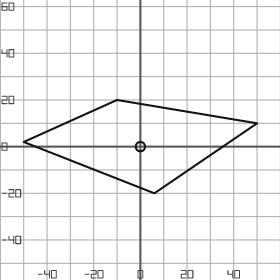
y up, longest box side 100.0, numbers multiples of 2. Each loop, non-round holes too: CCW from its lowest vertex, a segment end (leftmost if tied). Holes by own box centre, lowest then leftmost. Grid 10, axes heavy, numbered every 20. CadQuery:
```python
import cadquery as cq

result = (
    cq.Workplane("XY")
    .moveTo(6.0, -20.0)
    .lineTo(50.0, 10.0)
    .lineTo(-10.0, 20.0)
    .lineTo(-50.0, 2.0)
    .close()
    .moveTo(0.0, 0.0)
    .circle(2.0)
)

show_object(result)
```